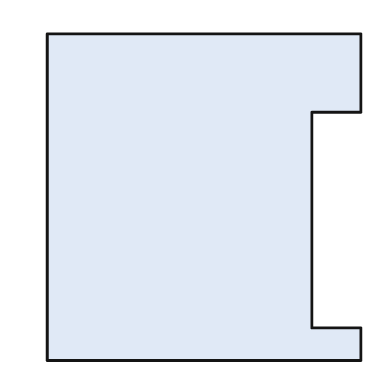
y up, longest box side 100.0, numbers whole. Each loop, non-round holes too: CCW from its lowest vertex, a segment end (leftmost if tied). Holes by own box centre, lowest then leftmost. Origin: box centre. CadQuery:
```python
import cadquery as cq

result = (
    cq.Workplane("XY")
    .moveTo(-48.0, -50.0)
    .lineTo(48.0, -50.0)
    .lineTo(48.0, -40.0)
    .lineTo(33.0, -40.0)
    .lineTo(33.0, 26.0)
    .lineTo(48.0, 26.0)
    .lineTo(48.0, 50.0)
    .lineTo(-48.0, 50.0)
    .close()
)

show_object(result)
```